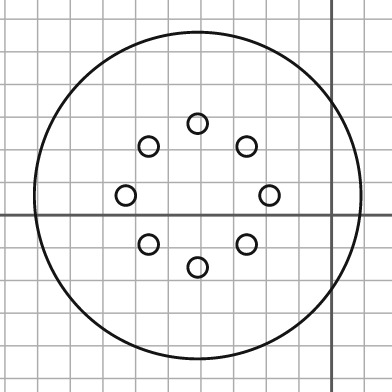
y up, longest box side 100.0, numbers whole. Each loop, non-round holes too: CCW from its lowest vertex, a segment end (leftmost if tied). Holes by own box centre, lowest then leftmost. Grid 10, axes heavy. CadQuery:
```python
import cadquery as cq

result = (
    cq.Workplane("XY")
    .moveTo(-41.0, 6.0)
    .circle(50.0)
    .moveTo(-41.0, -16.0)
    .circle(3.0)
    .moveTo(-56.0, -9.0)
    .circle(3.0)
    .moveTo(-26.0, -9.0)
    .circle(3.0)
    .moveTo(-63.0, 6.0)
    .circle(3.0)
    .moveTo(-19.0, 6.0)
    .circle(3.0)
    .moveTo(-56.0, 21.0)
    .circle(3.0)
    .moveTo(-26.0, 21.0)
    .circle(3.0)
    .moveTo(-41.0, 28.0)
    .circle(3.0)
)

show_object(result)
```